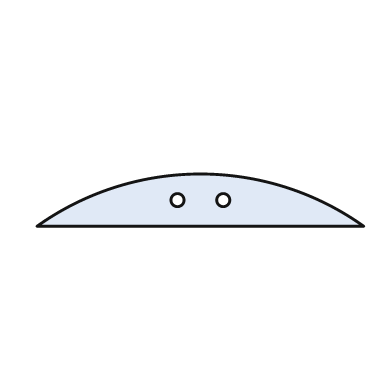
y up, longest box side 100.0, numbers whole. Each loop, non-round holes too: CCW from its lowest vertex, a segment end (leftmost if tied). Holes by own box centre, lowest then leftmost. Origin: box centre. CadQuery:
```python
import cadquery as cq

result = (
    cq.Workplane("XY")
    .moveTo(-50.0, -8.0)
    .lineTo(50.0, -8.0)
    .threePointArc((0.0, 8.0), (-50.0, -8.0))
    .close()
    .moveTo(-7.0, 0.0)
    .circle(2.0)
    .moveTo(7.0, 0.0)
    .circle(2.0)
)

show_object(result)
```